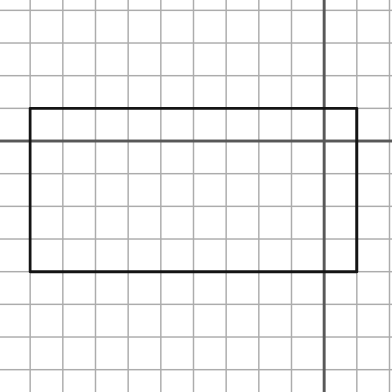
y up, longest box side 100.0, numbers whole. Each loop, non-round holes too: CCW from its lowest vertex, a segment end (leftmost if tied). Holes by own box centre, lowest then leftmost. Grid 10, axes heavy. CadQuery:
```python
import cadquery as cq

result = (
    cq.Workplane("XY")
    .moveTo(-90.0, -40.0)
    .lineTo(10.0, -40.0)
    .lineTo(10.0, 10.0)
    .lineTo(-90.0, 10.0)
    .close()
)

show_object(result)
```